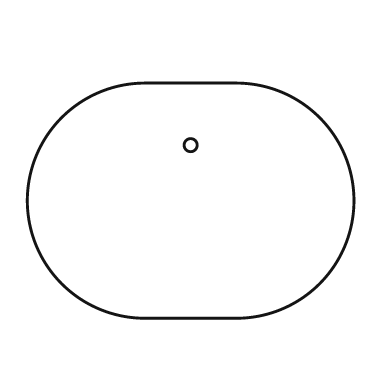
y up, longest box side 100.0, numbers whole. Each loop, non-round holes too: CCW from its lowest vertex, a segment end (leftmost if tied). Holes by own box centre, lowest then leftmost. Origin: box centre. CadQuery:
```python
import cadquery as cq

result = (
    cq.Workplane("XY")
    .moveTo(-14.0, -36.0)
    .lineTo(14.0, -36.0)
    .threePointArc((50.0, 0.0), (14.0, 36.0))
    .lineTo(-14.0, 36.0)
    .threePointArc((-50.0, 0.0), (-14.0, -36.0))
    .close()
    .moveTo(0.0, 17.0)
    .circle(2.0)
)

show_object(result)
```